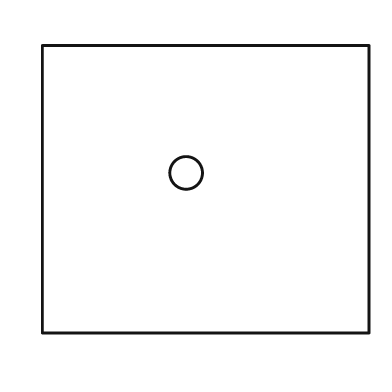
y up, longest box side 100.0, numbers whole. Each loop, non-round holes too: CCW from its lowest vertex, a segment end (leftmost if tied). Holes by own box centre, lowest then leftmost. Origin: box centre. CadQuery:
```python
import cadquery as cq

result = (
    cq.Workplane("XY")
    .moveTo(-50.0, -44.0)
    .lineTo(50.0, -44.0)
    .lineTo(50.0, 44.0)
    .lineTo(-50.0, 44.0)
    .close()
    .moveTo(-6.0, 5.0)
    .circle(5.0)
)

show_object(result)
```